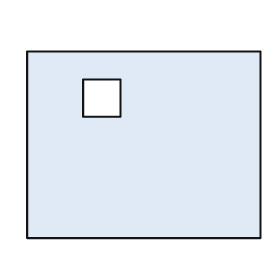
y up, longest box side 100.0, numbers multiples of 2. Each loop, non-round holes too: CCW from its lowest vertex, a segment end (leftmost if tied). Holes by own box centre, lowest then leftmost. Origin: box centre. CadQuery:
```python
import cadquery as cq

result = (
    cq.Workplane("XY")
    .moveTo(-50.0, -40.0)
    .lineTo(50.0, -40.0)
    .lineTo(50.0, 40.0)
    .lineTo(-50.0, 40.0)
    .close()
    .moveTo(-26.0, 12.0)
    .lineTo(-10.0, 12.0)
    .lineTo(-10.0, 28.0)
    .lineTo(-26.0, 28.0)
    .close()
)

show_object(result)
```